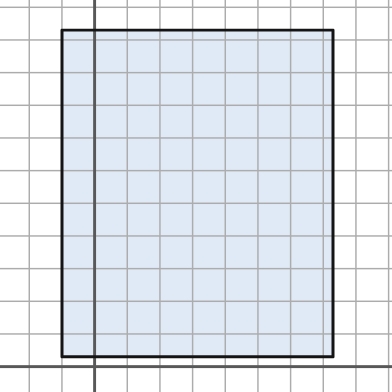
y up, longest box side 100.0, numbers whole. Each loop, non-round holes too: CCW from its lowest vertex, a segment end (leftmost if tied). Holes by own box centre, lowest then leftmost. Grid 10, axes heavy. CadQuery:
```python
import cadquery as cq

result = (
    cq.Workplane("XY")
    .moveTo(-10.0, 3.0)
    .lineTo(73.0, 3.0)
    .lineTo(73.0, 103.0)
    .lineTo(-10.0, 103.0)
    .close()
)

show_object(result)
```